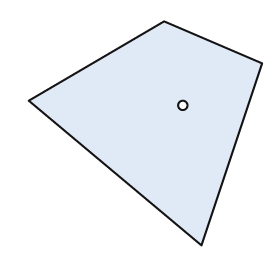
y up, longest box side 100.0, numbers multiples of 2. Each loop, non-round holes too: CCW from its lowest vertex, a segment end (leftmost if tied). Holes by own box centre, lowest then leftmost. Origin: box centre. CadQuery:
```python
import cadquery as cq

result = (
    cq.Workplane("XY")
    .moveTo(24.0, -48.0)
    .lineTo(50.0, 30.0)
    .lineTo(8.0, 48.0)
    .lineTo(-50.0, 14.0)
    .close()
    .moveTo(16.0, 12.0)
    .circle(2.0)
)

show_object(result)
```